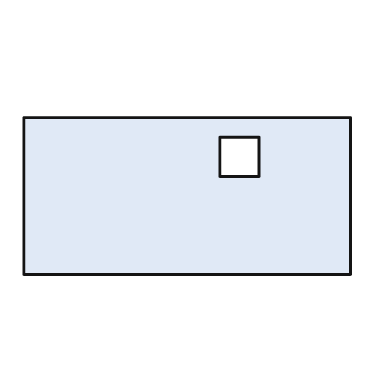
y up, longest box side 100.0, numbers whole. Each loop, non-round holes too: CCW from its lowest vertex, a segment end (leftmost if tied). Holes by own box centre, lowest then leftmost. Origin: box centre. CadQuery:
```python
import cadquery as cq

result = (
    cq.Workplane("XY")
    .moveTo(-50.0, -24.0)
    .lineTo(50.0, -24.0)
    .lineTo(50.0, 24.0)
    .lineTo(-50.0, 24.0)
    .close()
    .moveTo(10.0, 6.0)
    .lineTo(22.0, 6.0)
    .lineTo(22.0, 18.0)
    .lineTo(10.0, 18.0)
    .close()
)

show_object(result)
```